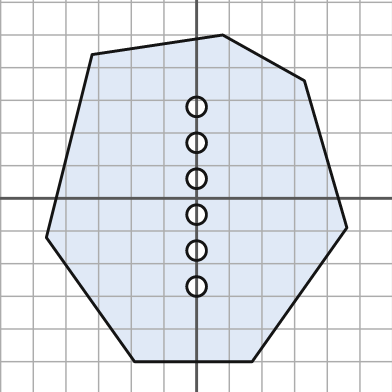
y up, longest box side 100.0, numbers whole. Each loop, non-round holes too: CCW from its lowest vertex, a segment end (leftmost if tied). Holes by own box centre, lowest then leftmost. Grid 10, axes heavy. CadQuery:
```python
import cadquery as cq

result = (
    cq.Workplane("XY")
    .moveTo(-19.0, -50.0)
    .lineTo(17.0, -50.0)
    .lineTo(46.0, -9.0)
    .lineTo(33.0, 36.0)
    .lineTo(8.0, 50.0)
    .lineTo(-32.0, 44.0)
    .lineTo(-46.0, -12.0)
    .close()
    .moveTo(0.0, -27.0)
    .circle(3.0)
    .moveTo(0.0, -16.0)
    .circle(3.0)
    .moveTo(0.0, -5.0)
    .circle(3.0)
    .moveTo(0.0, 6.0)
    .circle(3.0)
    .moveTo(0.0, 17.0)
    .circle(3.0)
    .moveTo(0.0, 28.0)
    .circle(3.0)
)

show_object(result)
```